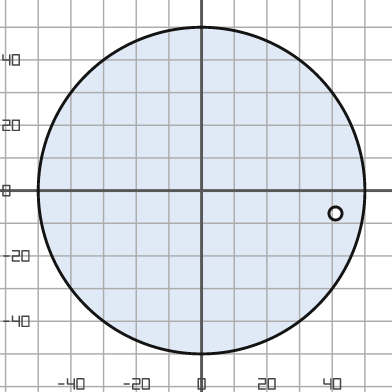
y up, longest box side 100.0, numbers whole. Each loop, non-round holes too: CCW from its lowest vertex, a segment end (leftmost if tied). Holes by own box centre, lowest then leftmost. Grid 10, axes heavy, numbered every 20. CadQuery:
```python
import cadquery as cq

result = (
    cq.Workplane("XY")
    .moveTo(0.0, 0.0)
    .circle(50.0)
    .moveTo(41.0, -7.0)
    .circle(2.0)
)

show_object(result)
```